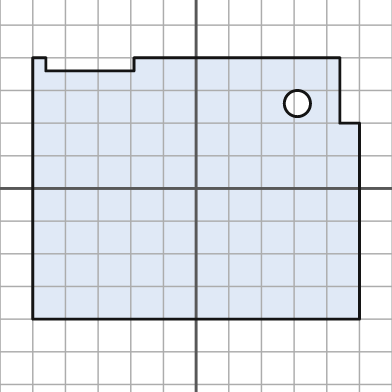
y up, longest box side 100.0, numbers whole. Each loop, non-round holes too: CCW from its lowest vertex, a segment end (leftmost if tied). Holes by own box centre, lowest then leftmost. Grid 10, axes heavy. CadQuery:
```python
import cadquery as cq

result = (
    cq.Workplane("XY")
    .moveTo(-50.0, -40.0)
    .lineTo(50.0, -40.0)
    .lineTo(50.0, 20.0)
    .lineTo(44.0, 20.0)
    .lineTo(44.0, 40.0)
    .lineTo(-19.0, 40.0)
    .lineTo(-19.0, 36.0)
    .lineTo(-46.0, 36.0)
    .lineTo(-46.0, 40.0)
    .lineTo(-50.0, 40.0)
    .close()
    .moveTo(31.0, 26.0)
    .circle(4.0)
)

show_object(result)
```